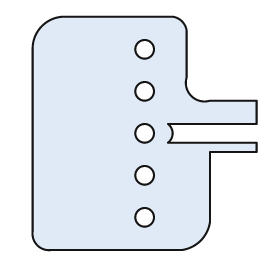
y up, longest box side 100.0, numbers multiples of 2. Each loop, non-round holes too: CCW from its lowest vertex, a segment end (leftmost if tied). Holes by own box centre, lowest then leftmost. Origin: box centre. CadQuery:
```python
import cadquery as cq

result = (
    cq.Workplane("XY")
    .moveTo(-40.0, -50.0)
    .lineTo(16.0, -50.0)
    .threePointArc((24.0, -46.0), (28.0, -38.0))
    .lineTo(28.0, -8.0)
    .lineTo(48.0, -8.0)
    .lineTo(48.0, -4.0)
    .lineTo(10.0, -4.0)
    .threePointArc((12.0, 0.0), (10.0, 4.0))
    .lineTo(48.0, 4.0)
    .lineTo(48.0, 14.0)
    .lineTo(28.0, 14.0)
    .threePointArc((20.0, 16.0), (18.0, 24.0))
    .lineTo(18.0, 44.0)
    .threePointArc((16.0, 48.0), (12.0, 50.0))
    .lineTo(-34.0, 50.0)
    .threePointArc((-44.0, 46.0), (-48.0, 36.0))
    .lineTo(-48.0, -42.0)
    .threePointArc((-46.0, -48.0), (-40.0, -50.0))
    .close()
    .moveTo(0.0, -36.0)
    .circle(4.0)
    .moveTo(0.0, -18.0)
    .circle(4.0)
    .moveTo(0.0, 0.0)
    .circle(4.0)
    .moveTo(0.0, 18.0)
    .circle(4.0)
    .moveTo(0.0, 36.0)
    .circle(4.0)
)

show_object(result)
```